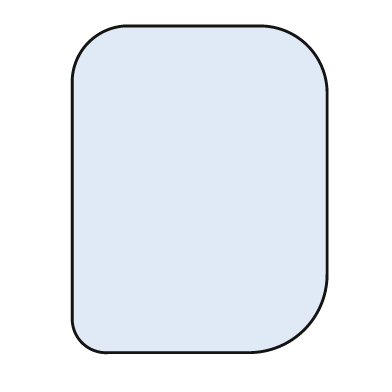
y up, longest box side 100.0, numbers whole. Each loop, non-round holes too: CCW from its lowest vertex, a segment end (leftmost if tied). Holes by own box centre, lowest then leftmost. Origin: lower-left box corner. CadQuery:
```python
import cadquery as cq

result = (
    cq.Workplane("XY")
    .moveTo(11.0, 0.0)
    .lineTo(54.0, 0.0)
    .threePointArc((71.0, 7.0), (78.0, 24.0))
    .lineTo(78.0, 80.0)
    .threePointArc((72.0, 94.0), (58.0, 100.0))
    .lineTo(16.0, 100.0)
    .threePointArc((5.0, 95.0), (0.0, 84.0))
    .lineTo(0.0, 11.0)
    .threePointArc((3.0, 3.0), (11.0, 0.0))
    .close()
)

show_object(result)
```